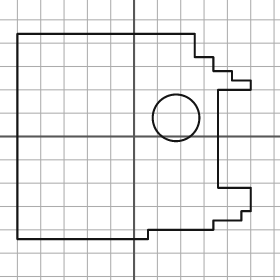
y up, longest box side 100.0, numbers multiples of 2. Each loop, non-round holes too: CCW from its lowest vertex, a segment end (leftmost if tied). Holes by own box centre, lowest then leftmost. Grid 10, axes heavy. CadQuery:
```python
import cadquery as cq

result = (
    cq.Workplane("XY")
    .moveTo(-50.0, -44.0)
    .lineTo(6.0, -44.0)
    .lineTo(6.0, -40.0)
    .lineTo(34.0, -40.0)
    .lineTo(34.0, -36.0)
    .lineTo(46.0, -36.0)
    .lineTo(46.0, -32.0)
    .lineTo(50.0, -32.0)
    .lineTo(50.0, -22.0)
    .lineTo(36.0, -22.0)
    .lineTo(36.0, 20.0)
    .lineTo(50.0, 20.0)
    .lineTo(50.0, 24.0)
    .lineTo(42.0, 24.0)
    .lineTo(42.0, 28.0)
    .lineTo(34.0, 28.0)
    .lineTo(34.0, 34.0)
    .lineTo(26.0, 34.0)
    .lineTo(26.0, 44.0)
    .lineTo(-50.0, 44.0)
    .close()
    .moveTo(18.0, 8.0)
    .circle(10.0)
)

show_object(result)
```